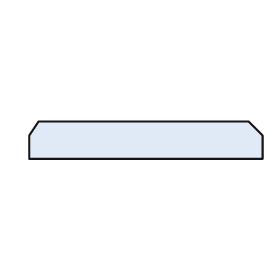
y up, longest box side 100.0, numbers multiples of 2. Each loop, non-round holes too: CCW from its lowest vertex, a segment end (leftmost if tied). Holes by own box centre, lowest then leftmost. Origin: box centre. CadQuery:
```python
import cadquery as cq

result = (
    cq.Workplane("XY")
    .moveTo(-50.0, -8.0)
    .lineTo(50.0, -8.0)
    .lineTo(50.0, 2.0)
    .lineTo(44.0, 8.0)
    .lineTo(-46.0, 8.0)
    .lineTo(-50.0, 2.0)
    .close()
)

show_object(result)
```